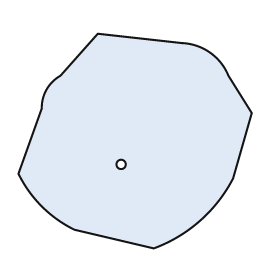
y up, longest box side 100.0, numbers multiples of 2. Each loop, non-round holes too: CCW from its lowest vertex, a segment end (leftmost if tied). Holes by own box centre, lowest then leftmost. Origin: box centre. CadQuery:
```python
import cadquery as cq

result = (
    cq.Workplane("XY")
    .moveTo(8.0, -46.0)
    .threePointArc((28.0, -34.0), (42.0, -16.0))
    .lineTo(50.0, 12.0)
    .lineTo(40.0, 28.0)
    .threePointArc((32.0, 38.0), (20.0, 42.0))
    .lineTo(-16.0, 46.0)
    .lineTo(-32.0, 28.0)
    .threePointArc((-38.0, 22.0), (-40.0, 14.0))
    .lineTo(-50.0, -14.0)
    .threePointArc((-40.0, -28.0), (-26.0, -38.0))
    .close()
    .moveTo(-6.0, -10.0)
    .circle(2.0)
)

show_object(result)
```